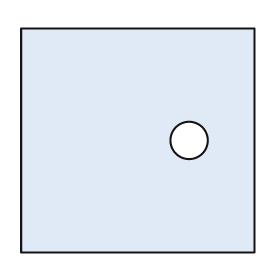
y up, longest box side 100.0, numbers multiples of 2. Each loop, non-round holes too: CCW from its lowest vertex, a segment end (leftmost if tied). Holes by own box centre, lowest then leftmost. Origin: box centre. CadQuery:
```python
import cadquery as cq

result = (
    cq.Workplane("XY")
    .moveTo(-50.0, -48.0)
    .lineTo(50.0, -48.0)
    .lineTo(50.0, 48.0)
    .lineTo(-50.0, 48.0)
    .close()
    .moveTo(22.0, 0.0)
    .circle(8.0)
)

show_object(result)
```